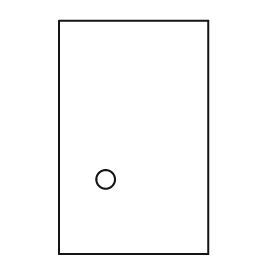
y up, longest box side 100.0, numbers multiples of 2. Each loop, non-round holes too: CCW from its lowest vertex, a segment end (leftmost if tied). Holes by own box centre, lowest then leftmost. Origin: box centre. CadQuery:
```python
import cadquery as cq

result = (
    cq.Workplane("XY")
    .moveTo(-32.0, -50.0)
    .lineTo(32.0, -50.0)
    .lineTo(32.0, 50.0)
    .lineTo(-32.0, 50.0)
    .close()
    .moveTo(-12.0, -18.0)
    .circle(4.0)
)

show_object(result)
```